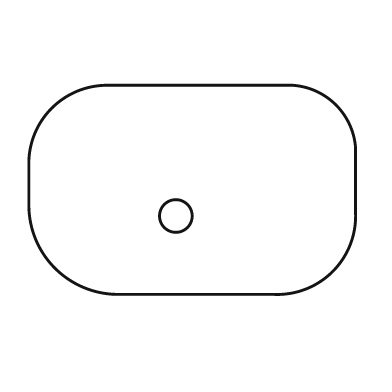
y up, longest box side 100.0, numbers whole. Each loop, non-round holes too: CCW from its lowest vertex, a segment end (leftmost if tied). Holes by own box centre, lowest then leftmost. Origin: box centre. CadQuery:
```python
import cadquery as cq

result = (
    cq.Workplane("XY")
    .moveTo(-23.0, -32.0)
    .lineTo(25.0, -32.0)
    .threePointArc((43.0, -25.0), (50.0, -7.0))
    .lineTo(50.0, 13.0)
    .threePointArc((44.0, 26.0), (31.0, 32.0))
    .lineTo(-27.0, 32.0)
    .threePointArc((-43.0, 25.0), (-50.0, 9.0))
    .lineTo(-50.0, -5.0)
    .threePointArc((-42.0, -24.0), (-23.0, -32.0))
    .close()
    .moveTo(-5.0, -8.0)
    .circle(5.0)
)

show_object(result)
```